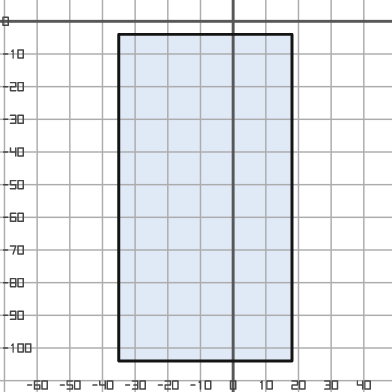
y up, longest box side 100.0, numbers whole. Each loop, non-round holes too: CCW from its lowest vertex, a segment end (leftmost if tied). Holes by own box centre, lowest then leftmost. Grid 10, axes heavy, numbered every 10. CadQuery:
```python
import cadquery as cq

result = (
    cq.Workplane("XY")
    .moveTo(-35.0, -104.0)
    .lineTo(18.0, -104.0)
    .lineTo(18.0, -4.0)
    .lineTo(-35.0, -4.0)
    .close()
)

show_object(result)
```